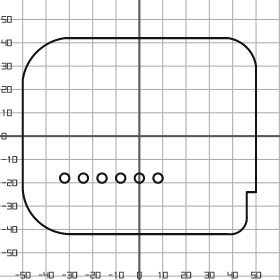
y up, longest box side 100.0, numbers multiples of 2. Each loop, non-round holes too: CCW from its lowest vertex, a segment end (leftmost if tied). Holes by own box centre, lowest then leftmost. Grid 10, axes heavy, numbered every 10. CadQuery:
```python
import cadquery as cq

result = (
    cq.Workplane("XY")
    .moveTo(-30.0, -42.0)
    .lineTo(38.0, -42.0)
    .threePointArc((44.0, -40.0), (46.0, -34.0))
    .lineTo(46.0, -24.0)
    .lineTo(50.0, -24.0)
    .lineTo(50.0, 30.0)
    .threePointArc((46.0, 38.0), (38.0, 42.0))
    .lineTo(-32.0, 42.0)
    .threePointArc((-44.0, 36.0), (-50.0, 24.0))
    .lineTo(-50.0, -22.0)
    .threePointArc((-44.0, -36.0), (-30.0, -42.0))
    .close()
    .moveTo(-32.0, -18.0)
    .circle(2.0)
    .moveTo(-24.0, -18.0)
    .circle(2.0)
    .moveTo(-16.0, -18.0)
    .circle(2.0)
    .moveTo(-8.0, -18.0)
    .circle(2.0)
    .moveTo(0.0, -18.0)
    .circle(2.0)
    .moveTo(8.0, -18.0)
    .circle(2.0)
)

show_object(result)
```